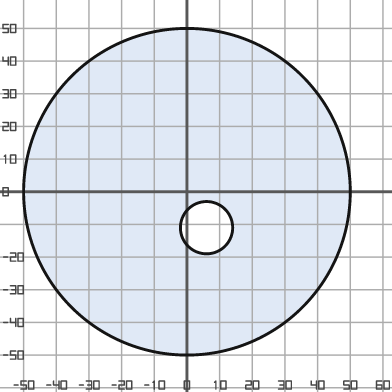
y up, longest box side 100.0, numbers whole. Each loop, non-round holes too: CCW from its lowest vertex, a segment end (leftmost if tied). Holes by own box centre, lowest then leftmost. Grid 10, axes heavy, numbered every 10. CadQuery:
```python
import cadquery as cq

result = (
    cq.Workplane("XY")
    .moveTo(0.0, 0.0)
    .circle(50.0)
    .moveTo(6.0, -11.0)
    .circle(8.0)
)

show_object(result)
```